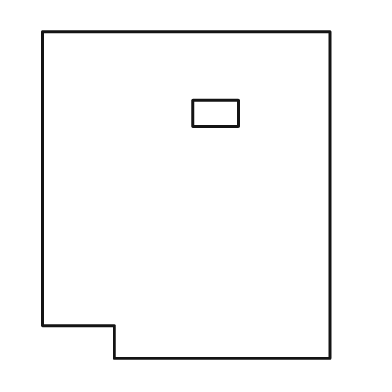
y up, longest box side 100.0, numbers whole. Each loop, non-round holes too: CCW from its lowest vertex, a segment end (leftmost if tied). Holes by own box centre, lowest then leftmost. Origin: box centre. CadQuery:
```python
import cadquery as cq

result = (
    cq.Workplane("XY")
    .moveTo(-22.0, -50.0)
    .lineTo(44.0, -50.0)
    .lineTo(44.0, 50.0)
    .lineTo(-44.0, 50.0)
    .lineTo(-44.0, -40.0)
    .lineTo(-22.0, -40.0)
    .close()
    .moveTo(2.0, 21.0)
    .lineTo(16.0, 21.0)
    .lineTo(16.0, 29.0)
    .lineTo(2.0, 29.0)
    .close()
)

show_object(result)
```